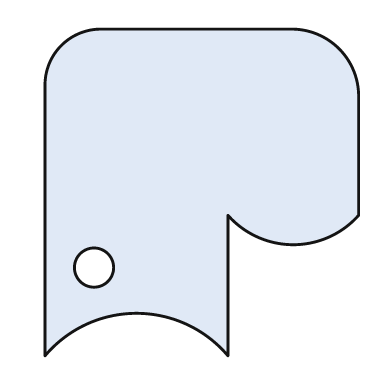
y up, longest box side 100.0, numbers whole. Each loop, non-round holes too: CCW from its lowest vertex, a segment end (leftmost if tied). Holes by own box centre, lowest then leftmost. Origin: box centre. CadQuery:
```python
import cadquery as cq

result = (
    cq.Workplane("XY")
    .moveTo(-48.0, -50.0)
    .threePointArc((-20.0, -37.0), (8.0, -50.0))
    .lineTo(8.0, -7.0)
    .threePointArc((28.0, -16.0), (48.0, -7.0))
    .lineTo(48.0, 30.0)
    .threePointArc((42.0, 44.0), (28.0, 50.0))
    .lineTo(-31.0, 50.0)
    .threePointArc((-43.0, 45.0), (-48.0, 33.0))
    .close()
    .moveTo(-33.0, -23.0)
    .circle(6.0)
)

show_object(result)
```